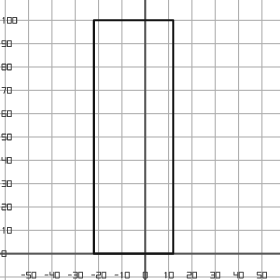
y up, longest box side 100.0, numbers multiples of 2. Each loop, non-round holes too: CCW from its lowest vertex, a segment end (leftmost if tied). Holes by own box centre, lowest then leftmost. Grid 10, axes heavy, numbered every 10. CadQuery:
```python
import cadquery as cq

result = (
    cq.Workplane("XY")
    .moveTo(-22.0, 0.0)
    .lineTo(12.0, 0.0)
    .lineTo(12.0, 100.0)
    .lineTo(-22.0, 100.0)
    .close()
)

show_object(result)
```